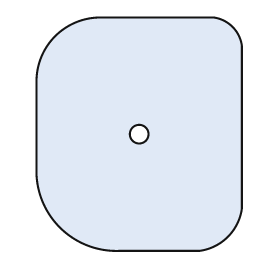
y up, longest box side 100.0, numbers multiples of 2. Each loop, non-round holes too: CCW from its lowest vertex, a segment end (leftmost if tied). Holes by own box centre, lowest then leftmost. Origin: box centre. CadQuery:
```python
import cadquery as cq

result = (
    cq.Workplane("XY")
    .moveTo(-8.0, -50.0)
    .lineTo(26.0, -50.0)
    .threePointArc((38.0, -44.0), (44.0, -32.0))
    .lineTo(44.0, 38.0)
    .threePointArc((40.0, 46.0), (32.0, 50.0))
    .lineTo(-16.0, 50.0)
    .threePointArc((-36.0, 42.0), (-44.0, 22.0))
    .lineTo(-44.0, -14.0)
    .threePointArc((-34.0, -40.0), (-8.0, -50.0))
    .close()
    .moveTo(0.0, 0.0)
    .circle(4.0)
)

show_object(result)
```